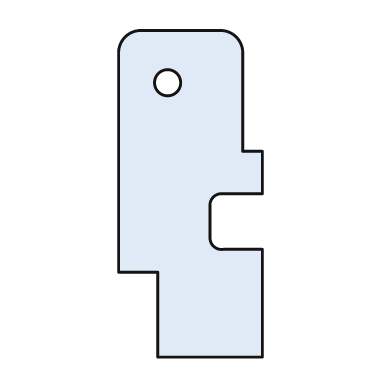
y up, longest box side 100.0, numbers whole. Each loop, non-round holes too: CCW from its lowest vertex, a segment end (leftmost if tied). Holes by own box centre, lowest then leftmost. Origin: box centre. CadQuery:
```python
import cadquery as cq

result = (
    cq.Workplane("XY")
    .moveTo(-10.0, -50.0)
    .lineTo(22.0, -50.0)
    .lineTo(22.0, -17.0)
    .lineTo(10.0, -17.0)
    .threePointArc((7.0, -16.0), (6.0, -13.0))
    .lineTo(6.0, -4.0)
    .threePointArc((7.0, -1.0), (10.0, 0.0))
    .lineTo(22.0, 0.0)
    .lineTo(22.0, 13.0)
    .lineTo(16.0, 13.0)
    .lineTo(16.0, 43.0)
    .threePointArc((14.0, 48.0), (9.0, 50.0))
    .lineTo(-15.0, 50.0)
    .threePointArc((-20.0, 48.0), (-22.0, 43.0))
    .lineTo(-22.0, -24.0)
    .lineTo(-10.0, -24.0)
    .close()
    .moveTo(-7.0, 34.0)
    .circle(4.0)
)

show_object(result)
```